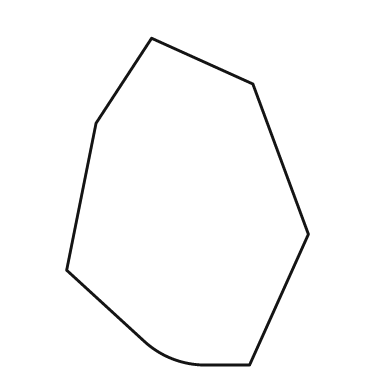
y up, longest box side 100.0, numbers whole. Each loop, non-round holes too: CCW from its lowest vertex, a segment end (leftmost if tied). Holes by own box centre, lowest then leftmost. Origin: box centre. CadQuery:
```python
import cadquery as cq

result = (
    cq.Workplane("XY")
    .moveTo(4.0, -50.0)
    .lineTo(19.0, -50.0)
    .lineTo(37.0, -10.0)
    .lineTo(20.0, 36.0)
    .lineTo(-11.0, 50.0)
    .lineTo(-28.0, 24.0)
    .lineTo(-37.0, -21.0)
    .lineTo(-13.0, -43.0)
    .threePointArc((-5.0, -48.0), (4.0, -50.0))
    .close()
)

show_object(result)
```